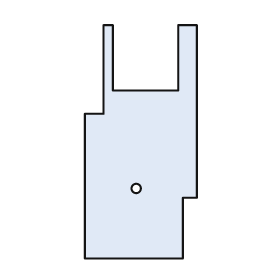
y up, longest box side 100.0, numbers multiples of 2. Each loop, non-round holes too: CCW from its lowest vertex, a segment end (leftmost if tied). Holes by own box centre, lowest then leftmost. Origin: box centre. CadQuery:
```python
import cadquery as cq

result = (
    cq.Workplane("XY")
    .moveTo(-24.0, -50.0)
    .lineTo(18.0, -50.0)
    .lineTo(18.0, -24.0)
    .lineTo(24.0, -24.0)
    .lineTo(24.0, 50.0)
    .lineTo(16.0, 50.0)
    .lineTo(16.0, 22.0)
    .lineTo(-12.0, 22.0)
    .lineTo(-12.0, 50.0)
    .lineTo(-16.0, 50.0)
    .lineTo(-16.0, 12.0)
    .lineTo(-24.0, 12.0)
    .close()
    .moveTo(-2.0, -20.0)
    .circle(2.0)
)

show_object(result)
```